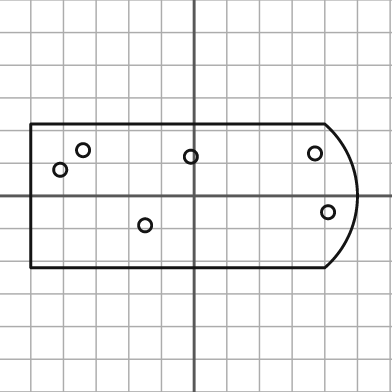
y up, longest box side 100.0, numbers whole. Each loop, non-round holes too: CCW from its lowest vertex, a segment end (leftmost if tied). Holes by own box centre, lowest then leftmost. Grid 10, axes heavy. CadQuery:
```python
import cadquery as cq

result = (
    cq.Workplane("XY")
    .moveTo(-50.0, -22.0)
    .lineTo(40.0, -22.0)
    .threePointArc((50.0, 0.0), (40.0, 22.0))
    .lineTo(-50.0, 22.0)
    .close()
    .moveTo(-15.0, -9.0)
    .circle(2.0)
    .moveTo(41.0, -5.0)
    .circle(2.0)
    .moveTo(-41.0, 8.0)
    .circle(2.0)
    .moveTo(-1.0, 12.0)
    .circle(2.0)
    .moveTo(37.0, 13.0)
    .circle(2.0)
    .moveTo(-34.0, 14.0)
    .circle(2.0)
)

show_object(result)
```